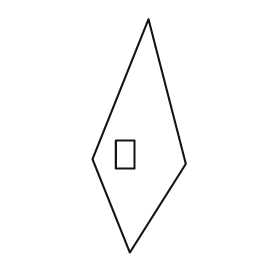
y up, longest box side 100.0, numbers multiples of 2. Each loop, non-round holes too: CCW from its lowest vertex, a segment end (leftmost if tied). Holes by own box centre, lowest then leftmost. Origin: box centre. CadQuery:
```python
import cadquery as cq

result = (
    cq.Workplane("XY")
    .moveTo(-4.0, -50.0)
    .lineTo(20.0, -12.0)
    .lineTo(4.0, 50.0)
    .lineTo(-20.0, -10.0)
    .close()
    .moveTo(-10.0, -14.0)
    .lineTo(-2.0, -14.0)
    .lineTo(-2.0, -2.0)
    .lineTo(-10.0, -2.0)
    .close()
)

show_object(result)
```